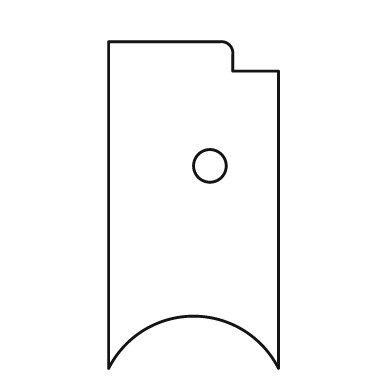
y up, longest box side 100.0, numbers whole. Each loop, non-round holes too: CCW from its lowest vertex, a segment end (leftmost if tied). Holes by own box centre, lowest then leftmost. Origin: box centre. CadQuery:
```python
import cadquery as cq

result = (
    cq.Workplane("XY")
    .moveTo(-26.0, -50.0)
    .threePointArc((0.0, -34.0), (26.0, -50.0))
    .lineTo(26.0, 41.0)
    .lineTo(12.0, 41.0)
    .lineTo(12.0, 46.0)
    .threePointArc((11.0, 49.0), (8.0, 50.0))
    .lineTo(-26.0, 50.0)
    .close()
    .moveTo(5.0, 12.0)
    .circle(5.0)
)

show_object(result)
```